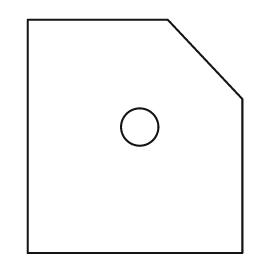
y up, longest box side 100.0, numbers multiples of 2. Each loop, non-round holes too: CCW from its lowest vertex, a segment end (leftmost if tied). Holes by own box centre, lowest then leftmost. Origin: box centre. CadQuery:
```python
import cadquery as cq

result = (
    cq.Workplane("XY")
    .moveTo(-46.0, -50.0)
    .lineTo(46.0, -50.0)
    .lineTo(46.0, 16.0)
    .lineTo(14.0, 50.0)
    .lineTo(-46.0, 50.0)
    .close()
    .moveTo(2.0, 4.0)
    .circle(8.0)
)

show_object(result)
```